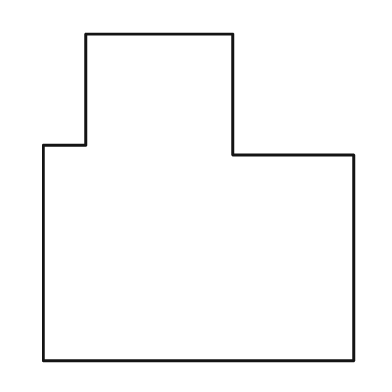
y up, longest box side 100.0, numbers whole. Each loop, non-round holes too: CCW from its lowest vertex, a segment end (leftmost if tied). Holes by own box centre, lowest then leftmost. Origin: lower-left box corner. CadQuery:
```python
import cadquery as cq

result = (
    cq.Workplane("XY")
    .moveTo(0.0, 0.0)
    .lineTo(95.0, 0.0)
    .lineTo(95.0, 63.0)
    .lineTo(58.0, 63.0)
    .lineTo(58.0, 100.0)
    .lineTo(13.0, 100.0)
    .lineTo(13.0, 66.0)
    .lineTo(0.0, 66.0)
    .close()
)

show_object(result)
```